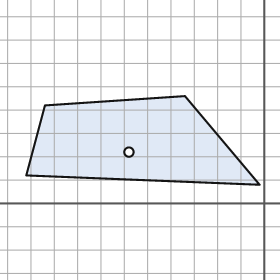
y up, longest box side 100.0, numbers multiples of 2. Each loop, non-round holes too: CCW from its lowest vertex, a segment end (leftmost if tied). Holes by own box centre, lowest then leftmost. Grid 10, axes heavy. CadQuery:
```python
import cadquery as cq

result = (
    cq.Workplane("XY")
    .moveTo(-2.0, 8.0)
    .lineTo(-34.0, 46.0)
    .lineTo(-94.0, 42.0)
    .lineTo(-102.0, 12.0)
    .close()
    .moveTo(-58.0, 22.0)
    .circle(2.0)
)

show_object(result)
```